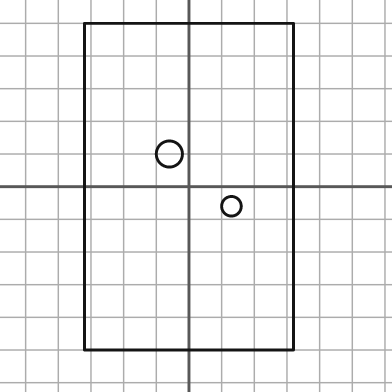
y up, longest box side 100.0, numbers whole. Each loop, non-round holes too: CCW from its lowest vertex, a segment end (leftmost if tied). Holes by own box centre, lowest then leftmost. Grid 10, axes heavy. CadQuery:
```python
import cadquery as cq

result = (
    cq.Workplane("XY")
    .moveTo(-32.0, -50.0)
    .lineTo(32.0, -50.0)
    .lineTo(32.0, 50.0)
    .lineTo(-32.0, 50.0)
    .close()
    .moveTo(13.0, -6.0)
    .circle(3.0)
    .moveTo(-6.0, 10.0)
    .circle(4.0)
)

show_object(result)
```